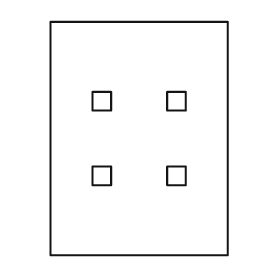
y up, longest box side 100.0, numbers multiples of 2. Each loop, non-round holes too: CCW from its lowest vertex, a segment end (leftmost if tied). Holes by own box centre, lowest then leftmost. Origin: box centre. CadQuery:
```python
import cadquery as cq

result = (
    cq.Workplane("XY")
    .moveTo(-38.0, -50.0)
    .lineTo(38.0, -50.0)
    .lineTo(38.0, 50.0)
    .lineTo(-38.0, 50.0)
    .close()
    .moveTo(-20.0, -20.0)
    .lineTo(-12.0, -20.0)
    .lineTo(-12.0, -12.0)
    .lineTo(-20.0, -12.0)
    .close()
    .moveTo(12.0, -20.0)
    .lineTo(20.0, -20.0)
    .lineTo(20.0, -12.0)
    .lineTo(12.0, -12.0)
    .close()
    .moveTo(-20.0, 12.0)
    .lineTo(-12.0, 12.0)
    .lineTo(-12.0, 20.0)
    .lineTo(-20.0, 20.0)
    .close()
    .moveTo(12.0, 12.0)
    .lineTo(20.0, 12.0)
    .lineTo(20.0, 20.0)
    .lineTo(12.0, 20.0)
    .close()
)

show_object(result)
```